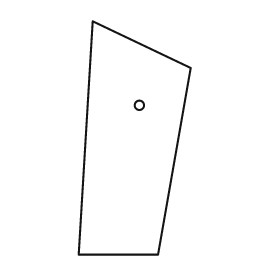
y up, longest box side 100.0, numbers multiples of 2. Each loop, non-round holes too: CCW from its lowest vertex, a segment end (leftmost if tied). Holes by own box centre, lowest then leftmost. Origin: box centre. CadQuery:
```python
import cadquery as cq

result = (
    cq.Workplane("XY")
    .moveTo(-24.0, -50.0)
    .lineTo(10.0, -50.0)
    .lineTo(24.0, 30.0)
    .lineTo(-18.0, 50.0)
    .close()
    .moveTo(2.0, 14.0)
    .circle(2.0)
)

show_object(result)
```